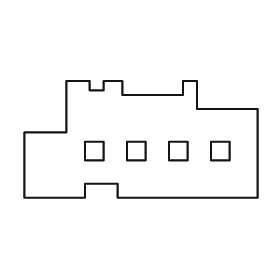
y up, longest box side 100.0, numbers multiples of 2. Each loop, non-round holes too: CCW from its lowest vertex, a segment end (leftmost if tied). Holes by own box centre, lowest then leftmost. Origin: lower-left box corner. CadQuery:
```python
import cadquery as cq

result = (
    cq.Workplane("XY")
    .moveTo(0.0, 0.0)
    .lineTo(26.0, 0.0)
    .lineTo(26.0, 6.0)
    .lineTo(40.0, 6.0)
    .lineTo(40.0, 0.0)
    .lineTo(100.0, 0.0)
    .lineTo(100.0, 38.0)
    .lineTo(74.0, 38.0)
    .lineTo(74.0, 50.0)
    .lineTo(68.0, 50.0)
    .lineTo(68.0, 44.0)
    .lineTo(42.0, 44.0)
    .lineTo(42.0, 50.0)
    .lineTo(34.0, 50.0)
    .lineTo(34.0, 46.0)
    .lineTo(28.0, 46.0)
    .lineTo(28.0, 50.0)
    .lineTo(18.0, 50.0)
    .lineTo(18.0, 28.0)
    .lineTo(0.0, 28.0)
    .close()
    .moveTo(26.0, 16.0)
    .lineTo(34.0, 16.0)
    .lineTo(34.0, 24.0)
    .lineTo(26.0, 24.0)
    .close()
    .moveTo(44.0, 16.0)
    .lineTo(52.0, 16.0)
    .lineTo(52.0, 24.0)
    .lineTo(44.0, 24.0)
    .close()
    .moveTo(62.0, 16.0)
    .lineTo(70.0, 16.0)
    .lineTo(70.0, 24.0)
    .lineTo(62.0, 24.0)
    .close()
    .moveTo(80.0, 16.0)
    .lineTo(88.0, 16.0)
    .lineTo(88.0, 24.0)
    .lineTo(80.0, 24.0)
    .close()
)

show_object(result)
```